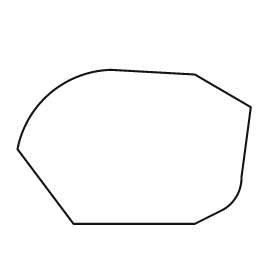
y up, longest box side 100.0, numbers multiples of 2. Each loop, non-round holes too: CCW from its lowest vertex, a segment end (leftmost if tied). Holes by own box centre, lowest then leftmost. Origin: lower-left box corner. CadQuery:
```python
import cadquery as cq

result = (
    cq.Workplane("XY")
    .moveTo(24.0, 0.0)
    .lineTo(76.0, 0.0)
    .lineTo(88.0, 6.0)
    .threePointArc((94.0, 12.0), (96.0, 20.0))
    .lineTo(100.0, 50.0)
    .lineTo(76.0, 64.0)
    .lineTo(40.0, 66.0)
    .threePointArc((14.0, 56.0), (0.0, 32.0))
    .close()
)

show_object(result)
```